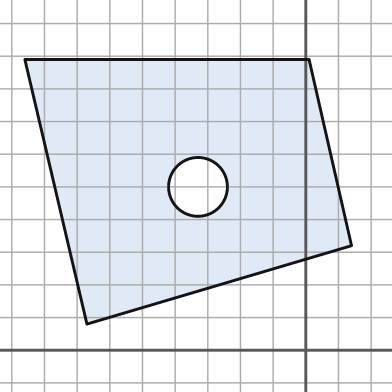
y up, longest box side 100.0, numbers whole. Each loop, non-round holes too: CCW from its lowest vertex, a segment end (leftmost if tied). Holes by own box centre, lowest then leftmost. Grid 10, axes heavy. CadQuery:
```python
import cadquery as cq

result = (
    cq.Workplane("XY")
    .moveTo(-67.0, 8.0)
    .lineTo(14.0, 32.0)
    .lineTo(1.0, 89.0)
    .lineTo(-86.0, 89.0)
    .close()
    .moveTo(-33.0, 50.0)
    .circle(9.0)
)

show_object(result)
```